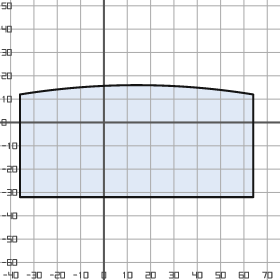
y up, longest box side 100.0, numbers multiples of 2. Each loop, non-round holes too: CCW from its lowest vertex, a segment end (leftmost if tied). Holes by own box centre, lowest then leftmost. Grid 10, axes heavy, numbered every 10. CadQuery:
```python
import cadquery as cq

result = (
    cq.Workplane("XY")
    .moveTo(-36.0, -32.0)
    .lineTo(64.0, -32.0)
    .lineTo(64.0, 12.0)
    .threePointArc((14.0, 16.0), (-36.0, 12.0))
    .close()
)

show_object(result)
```